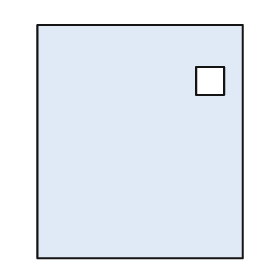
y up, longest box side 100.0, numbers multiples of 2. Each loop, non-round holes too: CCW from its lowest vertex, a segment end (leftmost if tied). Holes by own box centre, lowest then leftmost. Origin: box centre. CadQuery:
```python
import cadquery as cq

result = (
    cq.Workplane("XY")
    .moveTo(-44.0, -50.0)
    .lineTo(44.0, -50.0)
    .lineTo(44.0, 50.0)
    .lineTo(-44.0, 50.0)
    .close()
    .moveTo(24.0, 20.0)
    .lineTo(36.0, 20.0)
    .lineTo(36.0, 32.0)
    .lineTo(24.0, 32.0)
    .close()
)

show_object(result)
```